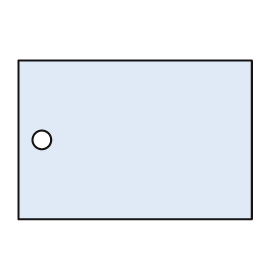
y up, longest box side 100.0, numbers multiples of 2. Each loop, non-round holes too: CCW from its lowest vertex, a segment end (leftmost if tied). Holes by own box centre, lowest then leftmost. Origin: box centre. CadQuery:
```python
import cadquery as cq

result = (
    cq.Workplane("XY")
    .moveTo(-50.0, -34.0)
    .lineTo(50.0, -34.0)
    .lineTo(50.0, 34.0)
    .lineTo(-50.0, 34.0)
    .close()
    .moveTo(-40.0, 0.0)
    .circle(4.0)
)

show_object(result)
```